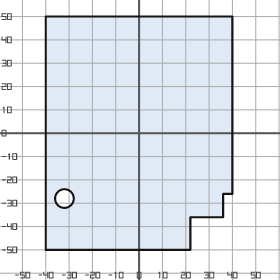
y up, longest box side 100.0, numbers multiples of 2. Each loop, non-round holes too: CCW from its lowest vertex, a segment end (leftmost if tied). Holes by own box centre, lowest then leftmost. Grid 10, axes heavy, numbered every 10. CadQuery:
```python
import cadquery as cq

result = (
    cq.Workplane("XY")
    .moveTo(-40.0, -50.0)
    .lineTo(22.0, -50.0)
    .lineTo(22.0, -36.0)
    .lineTo(36.0, -36.0)
    .lineTo(36.0, -26.0)
    .lineTo(40.0, -26.0)
    .lineTo(40.0, 50.0)
    .lineTo(-40.0, 50.0)
    .close()
    .moveTo(-32.0, -28.0)
    .circle(4.0)
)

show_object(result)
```